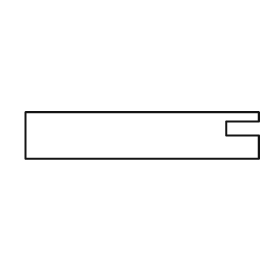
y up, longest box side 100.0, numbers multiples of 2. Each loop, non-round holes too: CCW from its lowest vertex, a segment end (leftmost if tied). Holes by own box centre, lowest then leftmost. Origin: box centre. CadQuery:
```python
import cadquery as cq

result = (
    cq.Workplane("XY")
    .moveTo(-50.0, -10.0)
    .lineTo(50.0, -10.0)
    .lineTo(50.0, 0.0)
    .lineTo(36.0, 0.0)
    .lineTo(36.0, 6.0)
    .lineTo(50.0, 6.0)
    .lineTo(50.0, 10.0)
    .lineTo(-50.0, 10.0)
    .close()
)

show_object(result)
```